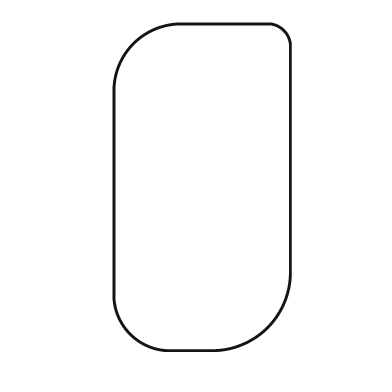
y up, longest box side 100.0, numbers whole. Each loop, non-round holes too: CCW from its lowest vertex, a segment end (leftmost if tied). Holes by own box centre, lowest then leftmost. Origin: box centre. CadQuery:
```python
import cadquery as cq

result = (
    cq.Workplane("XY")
    .moveTo(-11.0, -50.0)
    .lineTo(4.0, -50.0)
    .threePointArc((20.0, -43.0), (27.0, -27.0))
    .lineTo(27.0, 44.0)
    .threePointArc((25.0, 48.0), (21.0, 50.0))
    .lineTo(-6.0, 50.0)
    .threePointArc((-21.0, 44.0), (-27.0, 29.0))
    .lineTo(-27.0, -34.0)
    .threePointArc((-22.0, -45.0), (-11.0, -50.0))
    .close()
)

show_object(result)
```